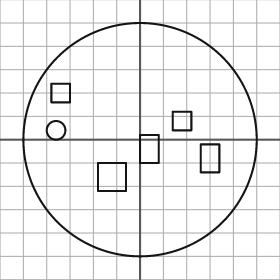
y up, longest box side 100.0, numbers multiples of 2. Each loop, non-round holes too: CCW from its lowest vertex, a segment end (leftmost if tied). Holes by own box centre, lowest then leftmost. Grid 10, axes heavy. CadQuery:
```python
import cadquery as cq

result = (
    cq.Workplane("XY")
    .moveTo(0.0, 0.0)
    .circle(50.0)
    .moveTo(-18.0, -22.0)
    .lineTo(-6.0, -22.0)
    .lineTo(-6.0, -10.0)
    .lineTo(-18.0, -10.0)
    .close()
    .moveTo(26.0, -14.0)
    .lineTo(34.0, -14.0)
    .lineTo(34.0, -2.0)
    .lineTo(26.0, -2.0)
    .close()
    .moveTo(0.0, -10.0)
    .lineTo(8.0, -10.0)
    .lineTo(8.0, 2.0)
    .lineTo(0.0, 2.0)
    .close()
    .moveTo(-36.0, 4.0)
    .circle(4.0)
    .moveTo(14.0, 4.0)
    .lineTo(22.0, 4.0)
    .lineTo(22.0, 12.0)
    .lineTo(14.0, 12.0)
    .close()
    .moveTo(-38.0, 16.0)
    .lineTo(-30.0, 16.0)
    .lineTo(-30.0, 24.0)
    .lineTo(-38.0, 24.0)
    .close()
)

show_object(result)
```